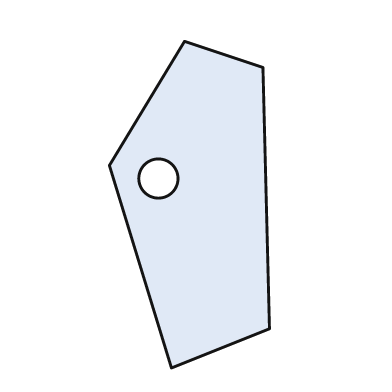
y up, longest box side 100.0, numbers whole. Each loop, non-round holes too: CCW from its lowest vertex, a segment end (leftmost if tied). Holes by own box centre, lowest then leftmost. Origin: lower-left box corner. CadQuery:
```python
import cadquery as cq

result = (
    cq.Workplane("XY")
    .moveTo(19.0, 0.0)
    .lineTo(49.0, 12.0)
    .lineTo(47.0, 92.0)
    .lineTo(23.0, 100.0)
    .lineTo(0.0, 62.0)
    .close()
    .moveTo(15.0, 58.0)
    .circle(6.0)
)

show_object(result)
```